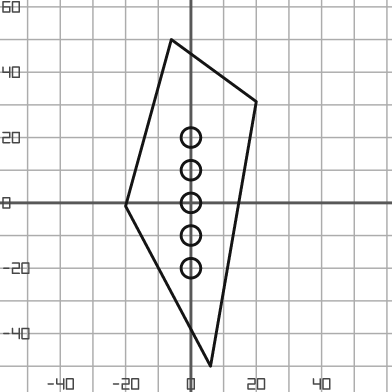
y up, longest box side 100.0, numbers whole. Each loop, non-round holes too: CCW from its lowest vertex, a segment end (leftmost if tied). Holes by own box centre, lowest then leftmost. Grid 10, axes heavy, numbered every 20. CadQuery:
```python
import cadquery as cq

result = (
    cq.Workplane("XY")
    .moveTo(6.0, -50.0)
    .lineTo(20.0, 31.0)
    .lineTo(-6.0, 50.0)
    .lineTo(-20.0, -1.0)
    .close()
    .moveTo(0.0, -20.0)
    .circle(3.0)
    .moveTo(0.0, -10.0)
    .circle(3.0)
    .moveTo(0.0, 0.0)
    .circle(3.0)
    .moveTo(0.0, 10.0)
    .circle(3.0)
    .moveTo(0.0, 20.0)
    .circle(3.0)
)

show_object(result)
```